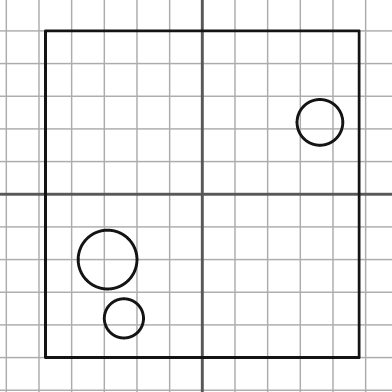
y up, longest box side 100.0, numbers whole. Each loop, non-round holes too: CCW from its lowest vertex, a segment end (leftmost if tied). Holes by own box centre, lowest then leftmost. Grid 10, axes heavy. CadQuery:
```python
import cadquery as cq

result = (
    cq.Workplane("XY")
    .moveTo(-48.0, -50.0)
    .lineTo(48.0, -50.0)
    .lineTo(48.0, 50.0)
    .lineTo(-48.0, 50.0)
    .close()
    .moveTo(-24.0, -38.0)
    .circle(6.0)
    .moveTo(-29.0, -20.0)
    .circle(9.0)
    .moveTo(36.0, 22.0)
    .circle(7.0)
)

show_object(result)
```